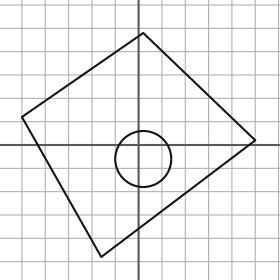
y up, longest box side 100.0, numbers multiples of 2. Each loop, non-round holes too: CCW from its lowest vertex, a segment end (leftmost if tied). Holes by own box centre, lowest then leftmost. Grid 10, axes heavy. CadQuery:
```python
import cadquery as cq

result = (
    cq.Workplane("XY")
    .moveTo(-16.0, -48.0)
    .lineTo(50.0, 2.0)
    .lineTo(2.0, 48.0)
    .lineTo(-50.0, 12.0)
    .close()
    .moveTo(2.0, -6.0)
    .circle(12.0)
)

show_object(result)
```